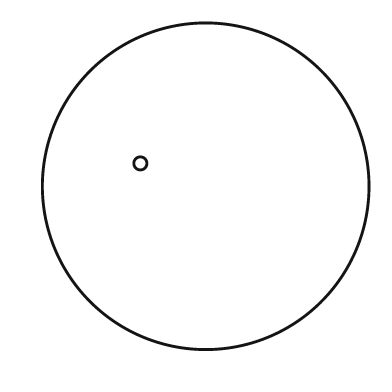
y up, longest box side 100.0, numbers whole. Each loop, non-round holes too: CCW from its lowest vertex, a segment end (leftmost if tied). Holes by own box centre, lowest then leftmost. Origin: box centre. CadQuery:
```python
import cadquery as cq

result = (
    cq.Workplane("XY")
    .moveTo(0.0, 0.0)
    .circle(50.0)
    .moveTo(-20.0, 7.0)
    .circle(2.0)
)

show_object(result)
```